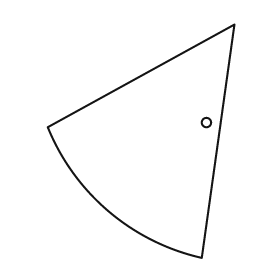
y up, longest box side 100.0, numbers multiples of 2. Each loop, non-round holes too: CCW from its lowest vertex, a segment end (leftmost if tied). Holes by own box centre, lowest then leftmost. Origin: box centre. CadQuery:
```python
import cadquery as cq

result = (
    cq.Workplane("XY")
    .moveTo(26.0, -50.0)
    .lineTo(40.0, 50.0)
    .lineTo(-40.0, 6.0)
    .threePointArc((-14.0, -30.0), (26.0, -50.0))
    .close()
    .moveTo(28.0, 8.0)
    .circle(2.0)
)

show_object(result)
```